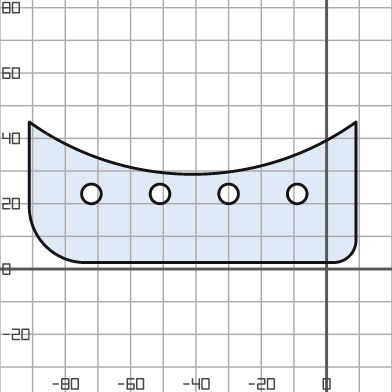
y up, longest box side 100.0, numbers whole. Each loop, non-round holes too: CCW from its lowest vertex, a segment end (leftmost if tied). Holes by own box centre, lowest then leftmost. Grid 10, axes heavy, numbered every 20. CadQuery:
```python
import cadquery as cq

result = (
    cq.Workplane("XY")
    .moveTo(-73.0, 2.0)
    .lineTo(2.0, 2.0)
    .threePointArc((7.0, 4.0), (9.0, 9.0))
    .lineTo(9.0, 45.0)
    .threePointArc((-41.0, 29.0), (-91.0, 45.0))
    .lineTo(-91.0, 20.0)
    .threePointArc((-86.0, 7.0), (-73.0, 2.0))
    .close()
    .moveTo(-72.0, 23.0)
    .circle(3.0)
    .moveTo(-51.0, 23.0)
    .circle(3.0)
    .moveTo(-30.0, 23.0)
    .circle(3.0)
    .moveTo(-9.0, 23.0)
    .circle(3.0)
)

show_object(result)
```